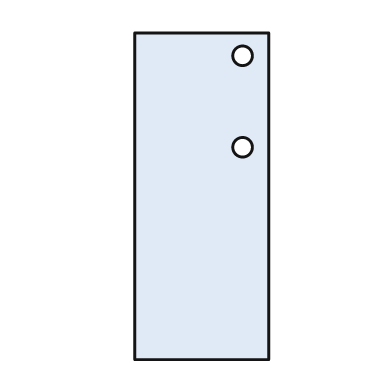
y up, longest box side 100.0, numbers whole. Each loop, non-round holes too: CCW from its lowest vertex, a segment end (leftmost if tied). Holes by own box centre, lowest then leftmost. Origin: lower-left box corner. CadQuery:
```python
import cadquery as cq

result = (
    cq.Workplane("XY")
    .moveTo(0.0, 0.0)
    .lineTo(41.0, 0.0)
    .lineTo(41.0, 100.0)
    .lineTo(0.0, 100.0)
    .close()
    .moveTo(33.0, 65.0)
    .circle(3.0)
    .moveTo(33.0, 93.0)
    .circle(3.0)
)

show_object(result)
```